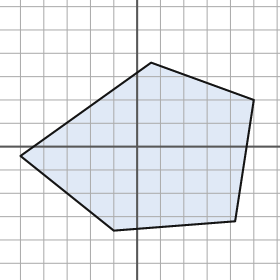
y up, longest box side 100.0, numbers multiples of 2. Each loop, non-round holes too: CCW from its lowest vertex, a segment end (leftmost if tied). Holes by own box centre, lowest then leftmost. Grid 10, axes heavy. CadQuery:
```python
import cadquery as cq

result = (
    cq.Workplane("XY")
    .moveTo(-10.0, -36.0)
    .lineTo(42.0, -32.0)
    .lineTo(50.0, 20.0)
    .lineTo(6.0, 36.0)
    .lineTo(-50.0, -4.0)
    .close()
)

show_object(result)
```